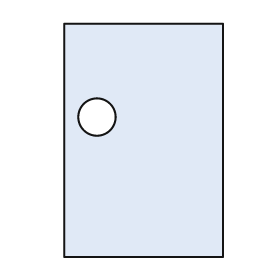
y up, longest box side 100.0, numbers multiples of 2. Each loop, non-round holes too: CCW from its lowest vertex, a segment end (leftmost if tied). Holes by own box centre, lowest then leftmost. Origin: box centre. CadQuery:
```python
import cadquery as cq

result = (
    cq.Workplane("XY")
    .moveTo(-34.0, -50.0)
    .lineTo(34.0, -50.0)
    .lineTo(34.0, 50.0)
    .lineTo(-34.0, 50.0)
    .close()
    .moveTo(-20.0, 10.0)
    .circle(8.0)
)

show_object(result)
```